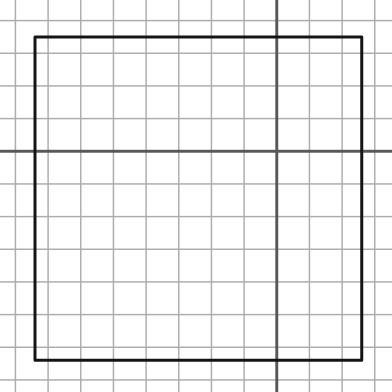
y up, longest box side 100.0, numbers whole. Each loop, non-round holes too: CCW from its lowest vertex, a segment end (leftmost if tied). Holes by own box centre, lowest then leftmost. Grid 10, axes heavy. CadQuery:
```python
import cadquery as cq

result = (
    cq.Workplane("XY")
    .moveTo(-74.0, -64.0)
    .lineTo(26.0, -64.0)
    .lineTo(26.0, 35.0)
    .lineTo(-74.0, 35.0)
    .close()
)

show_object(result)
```